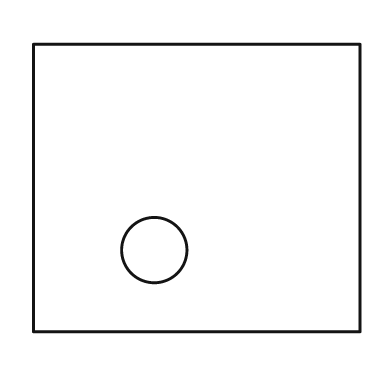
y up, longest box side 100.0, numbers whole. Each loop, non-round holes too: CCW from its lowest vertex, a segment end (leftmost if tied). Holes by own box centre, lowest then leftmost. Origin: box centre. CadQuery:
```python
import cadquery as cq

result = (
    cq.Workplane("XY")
    .moveTo(-50.0, -44.0)
    .lineTo(50.0, -44.0)
    .lineTo(50.0, 44.0)
    .lineTo(-50.0, 44.0)
    .close()
    .moveTo(-13.0, -19.0)
    .circle(10.0)
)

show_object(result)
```